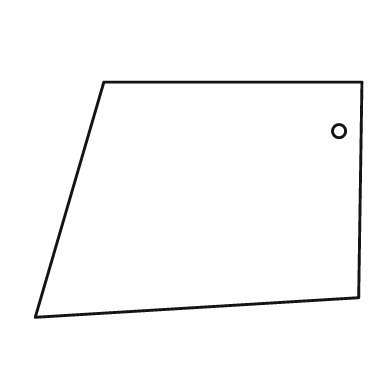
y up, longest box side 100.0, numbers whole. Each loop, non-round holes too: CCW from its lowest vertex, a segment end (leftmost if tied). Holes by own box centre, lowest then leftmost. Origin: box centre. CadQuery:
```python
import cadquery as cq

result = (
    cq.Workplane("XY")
    .moveTo(-50.0, -36.0)
    .lineTo(49.0, -30.0)
    .lineTo(50.0, 36.0)
    .lineTo(-29.0, 36.0)
    .close()
    .moveTo(43.0, 21.0)
    .circle(2.0)
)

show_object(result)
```